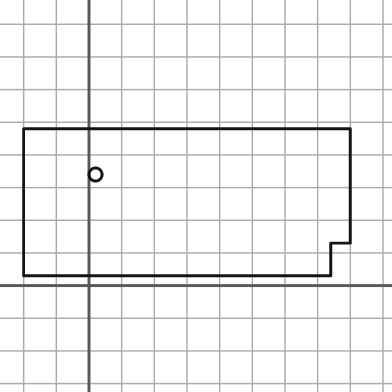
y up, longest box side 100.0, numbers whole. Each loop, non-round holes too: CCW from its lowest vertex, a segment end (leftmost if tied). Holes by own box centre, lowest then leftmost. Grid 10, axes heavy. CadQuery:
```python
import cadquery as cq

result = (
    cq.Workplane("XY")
    .moveTo(-20.0, 3.0)
    .lineTo(74.0, 3.0)
    .lineTo(74.0, 13.0)
    .lineTo(80.0, 13.0)
    .lineTo(80.0, 48.0)
    .lineTo(-20.0, 48.0)
    .close()
    .moveTo(2.0, 34.0)
    .circle(2.0)
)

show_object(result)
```